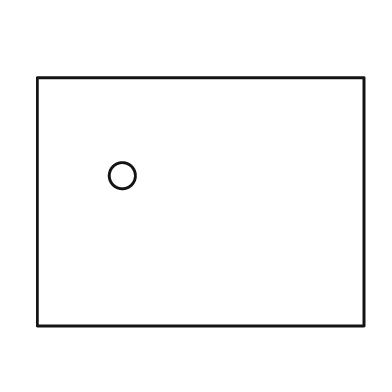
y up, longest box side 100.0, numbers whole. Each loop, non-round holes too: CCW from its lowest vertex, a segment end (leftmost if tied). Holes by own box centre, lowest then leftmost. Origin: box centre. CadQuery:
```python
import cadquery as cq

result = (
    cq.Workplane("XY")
    .moveTo(-50.0, -38.0)
    .lineTo(50.0, -38.0)
    .lineTo(50.0, 38.0)
    .lineTo(-50.0, 38.0)
    .close()
    .moveTo(-24.0, 8.0)
    .circle(4.0)
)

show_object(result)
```